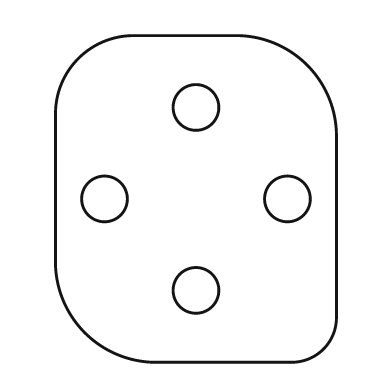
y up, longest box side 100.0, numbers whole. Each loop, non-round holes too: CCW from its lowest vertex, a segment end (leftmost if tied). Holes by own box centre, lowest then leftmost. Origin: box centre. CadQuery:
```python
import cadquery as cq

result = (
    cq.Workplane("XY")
    .moveTo(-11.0, -50.0)
    .lineTo(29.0, -50.0)
    .threePointArc((39.0, -46.0), (43.0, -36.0))
    .lineTo(43.0, 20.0)
    .threePointArc((34.0, 41.0), (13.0, 50.0))
    .lineTo(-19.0, 50.0)
    .threePointArc((-36.0, 43.0), (-43.0, 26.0))
    .lineTo(-43.0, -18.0)
    .threePointArc((-34.0, -41.0), (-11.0, -50.0))
    .close()
    .moveTo(0.0, -28.0)
    .circle(7.0)
    .moveTo(-28.0, 0.0)
    .circle(7.0)
    .moveTo(28.0, 0.0)
    .circle(7.0)
    .moveTo(0.0, 28.0)
    .circle(7.0)
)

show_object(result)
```